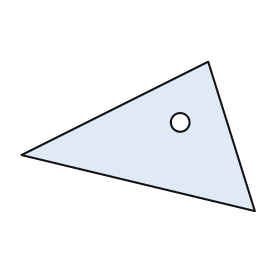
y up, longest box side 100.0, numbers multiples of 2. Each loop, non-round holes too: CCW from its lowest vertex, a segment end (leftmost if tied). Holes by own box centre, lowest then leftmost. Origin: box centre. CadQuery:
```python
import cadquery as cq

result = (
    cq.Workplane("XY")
    .moveTo(50.0, -32.0)
    .lineTo(30.0, 32.0)
    .lineTo(-50.0, -8.0)
    .close()
    .moveTo(18.0, 6.0)
    .circle(4.0)
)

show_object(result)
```